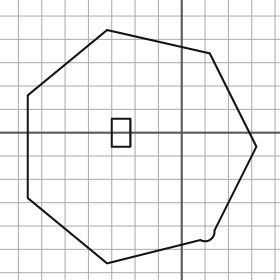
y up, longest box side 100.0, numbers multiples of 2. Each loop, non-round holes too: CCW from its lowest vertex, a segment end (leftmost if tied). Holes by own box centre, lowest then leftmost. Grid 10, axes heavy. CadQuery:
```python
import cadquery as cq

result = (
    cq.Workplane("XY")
    .moveTo(-32.0, -56.0)
    .lineTo(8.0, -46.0)
    .threePointArc((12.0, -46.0), (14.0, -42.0))
    .lineTo(32.0, -6.0)
    .lineTo(12.0, 34.0)
    .lineTo(-32.0, 44.0)
    .lineTo(-66.0, 16.0)
    .lineTo(-66.0, -28.0)
    .close()
    .moveTo(-30.0, -6.0)
    .lineTo(-22.0, -6.0)
    .lineTo(-22.0, 6.0)
    .lineTo(-30.0, 6.0)
    .close()
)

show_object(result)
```